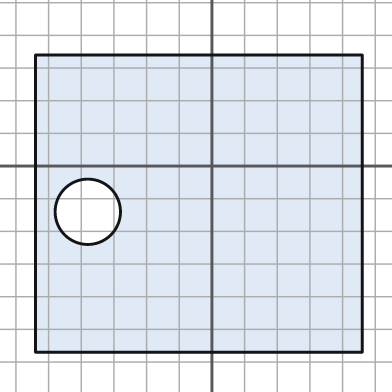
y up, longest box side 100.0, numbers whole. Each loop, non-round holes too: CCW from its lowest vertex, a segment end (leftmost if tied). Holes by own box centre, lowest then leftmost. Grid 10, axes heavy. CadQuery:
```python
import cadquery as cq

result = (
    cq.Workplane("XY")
    .moveTo(-54.0, -57.0)
    .lineTo(46.0, -57.0)
    .lineTo(46.0, 34.0)
    .lineTo(-54.0, 34.0)
    .close()
    .moveTo(-38.0, -14.0)
    .circle(10.0)
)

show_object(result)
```